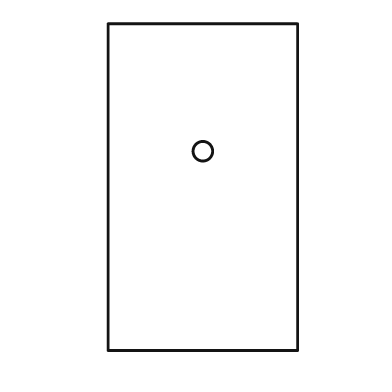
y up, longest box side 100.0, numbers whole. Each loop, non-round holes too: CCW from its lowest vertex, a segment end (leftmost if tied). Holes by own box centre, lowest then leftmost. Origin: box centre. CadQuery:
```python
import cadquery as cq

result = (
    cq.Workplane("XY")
    .moveTo(-29.0, -50.0)
    .lineTo(29.0, -50.0)
    .lineTo(29.0, 50.0)
    .lineTo(-29.0, 50.0)
    .close()
    .moveTo(0.0, 11.0)
    .circle(3.0)
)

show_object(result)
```